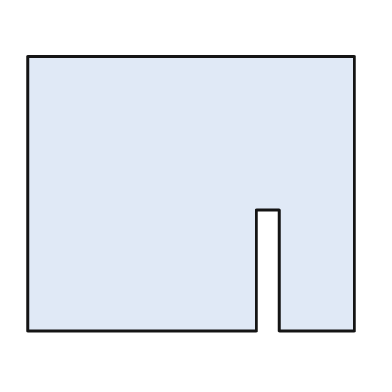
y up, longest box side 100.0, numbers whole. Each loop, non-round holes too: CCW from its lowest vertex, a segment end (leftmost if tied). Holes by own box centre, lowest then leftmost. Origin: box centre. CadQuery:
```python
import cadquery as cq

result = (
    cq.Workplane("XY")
    .moveTo(-50.0, -42.0)
    .lineTo(20.0, -42.0)
    .lineTo(20.0, -5.0)
    .lineTo(27.0, -5.0)
    .lineTo(27.0, -42.0)
    .lineTo(50.0, -42.0)
    .lineTo(50.0, 42.0)
    .lineTo(-50.0, 42.0)
    .close()
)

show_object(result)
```